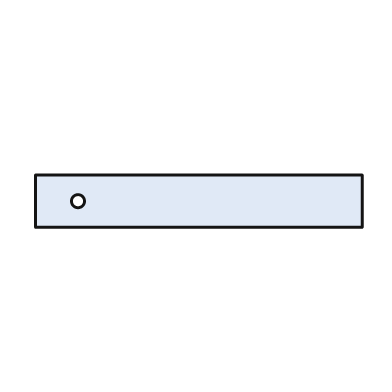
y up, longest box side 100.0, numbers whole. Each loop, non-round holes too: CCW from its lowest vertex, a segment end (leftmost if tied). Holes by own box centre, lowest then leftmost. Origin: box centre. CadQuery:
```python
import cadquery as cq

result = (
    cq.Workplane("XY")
    .moveTo(-50.0, -8.0)
    .lineTo(50.0, -8.0)
    .lineTo(50.0, 8.0)
    .lineTo(-50.0, 8.0)
    .close()
    .moveTo(-37.0, 0.0)
    .circle(2.0)
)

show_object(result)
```